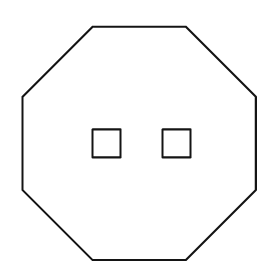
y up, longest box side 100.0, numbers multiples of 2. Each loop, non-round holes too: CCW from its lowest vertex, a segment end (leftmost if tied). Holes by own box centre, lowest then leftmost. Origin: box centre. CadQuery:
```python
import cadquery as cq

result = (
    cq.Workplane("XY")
    .moveTo(-20.0, -50.0)
    .lineTo(20.0, -50.0)
    .lineTo(50.0, -20.0)
    .lineTo(50.0, 20.0)
    .lineTo(20.0, 50.0)
    .lineTo(-20.0, 50.0)
    .lineTo(-50.0, 20.0)
    .lineTo(-50.0, -20.0)
    .close()
    .moveTo(-20.0, -6.0)
    .lineTo(-8.0, -6.0)
    .lineTo(-8.0, 6.0)
    .lineTo(-20.0, 6.0)
    .close()
    .moveTo(10.0, -6.0)
    .lineTo(22.0, -6.0)
    .lineTo(22.0, 6.0)
    .lineTo(10.0, 6.0)
    .close()
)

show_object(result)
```